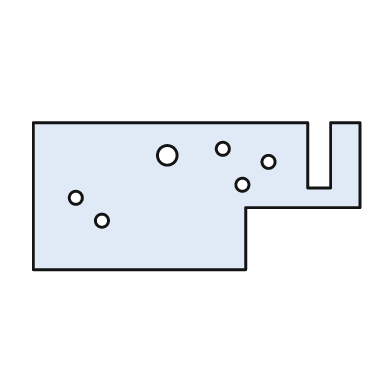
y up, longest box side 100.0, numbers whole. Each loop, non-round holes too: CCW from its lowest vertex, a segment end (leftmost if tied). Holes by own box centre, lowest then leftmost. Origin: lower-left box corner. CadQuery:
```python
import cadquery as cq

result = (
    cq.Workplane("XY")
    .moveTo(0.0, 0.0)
    .lineTo(65.0, 0.0)
    .lineTo(65.0, 19.0)
    .lineTo(100.0, 19.0)
    .lineTo(100.0, 45.0)
    .lineTo(91.0, 45.0)
    .lineTo(91.0, 25.0)
    .lineTo(84.0, 25.0)
    .lineTo(84.0, 45.0)
    .lineTo(0.0, 45.0)
    .close()
    .moveTo(21.0, 15.0)
    .circle(2.0)
    .moveTo(13.0, 22.0)
    .circle(2.0)
    .moveTo(64.0, 26.0)
    .circle(2.0)
    .moveTo(72.0, 33.0)
    .circle(2.0)
    .moveTo(41.0, 35.0)
    .circle(3.0)
    .moveTo(58.0, 37.0)
    .circle(2.0)
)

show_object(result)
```